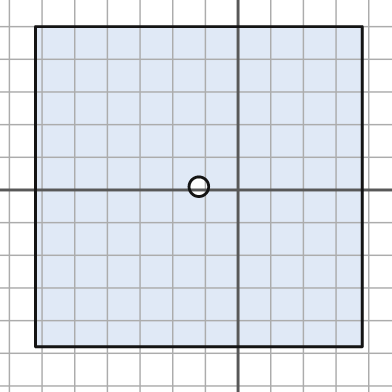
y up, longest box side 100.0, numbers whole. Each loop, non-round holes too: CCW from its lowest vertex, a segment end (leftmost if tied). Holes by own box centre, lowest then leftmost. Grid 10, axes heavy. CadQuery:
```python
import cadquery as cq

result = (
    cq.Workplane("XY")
    .moveTo(-62.0, -48.0)
    .lineTo(38.0, -48.0)
    .lineTo(38.0, 50.0)
    .lineTo(-62.0, 50.0)
    .close()
    .moveTo(-12.0, 1.0)
    .circle(3.0)
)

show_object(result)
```